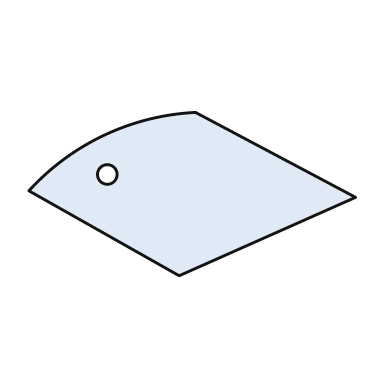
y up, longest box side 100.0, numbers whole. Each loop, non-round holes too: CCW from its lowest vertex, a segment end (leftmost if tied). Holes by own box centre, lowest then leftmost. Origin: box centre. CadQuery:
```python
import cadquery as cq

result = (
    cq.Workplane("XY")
    .moveTo(-4.0, -25.0)
    .lineTo(50.0, -1.0)
    .lineTo(1.0, 25.0)
    .threePointArc((-27.0, 18.0), (-50.0, 1.0))
    .close()
    .moveTo(-26.0, 6.0)
    .circle(3.0)
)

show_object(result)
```